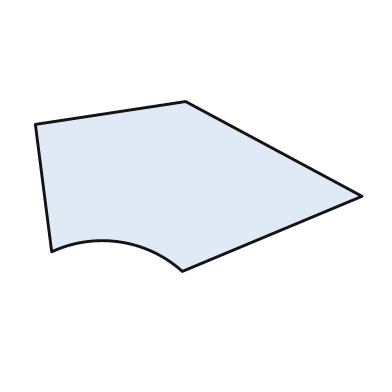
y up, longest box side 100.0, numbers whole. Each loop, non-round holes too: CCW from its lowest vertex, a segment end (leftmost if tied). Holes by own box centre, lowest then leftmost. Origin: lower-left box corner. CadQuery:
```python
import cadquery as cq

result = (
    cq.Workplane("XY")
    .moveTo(45.0, 0.0)
    .lineTo(100.0, 23.0)
    .lineTo(46.0, 52.0)
    .lineTo(0.0, 45.0)
    .lineTo(5.0, 6.0)
    .threePointArc((26.0, 9.0), (45.0, 0.0))
    .close()
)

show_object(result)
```